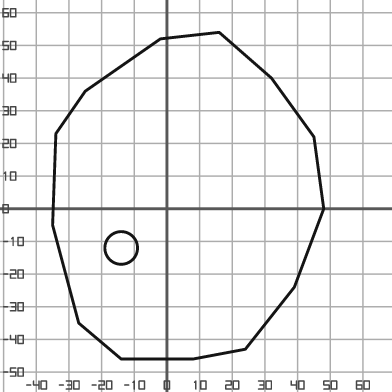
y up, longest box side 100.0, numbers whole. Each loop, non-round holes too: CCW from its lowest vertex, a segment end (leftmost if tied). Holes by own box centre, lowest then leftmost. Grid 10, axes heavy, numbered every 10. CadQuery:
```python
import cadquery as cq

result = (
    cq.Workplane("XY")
    .moveTo(-14.0, -46.0)
    .lineTo(8.0, -46.0)
    .lineTo(24.0, -43.0)
    .lineTo(39.0, -24.0)
    .lineTo(48.0, 0.0)
    .lineTo(45.0, 22.0)
    .lineTo(32.0, 40.0)
    .lineTo(16.0, 54.0)
    .lineTo(-2.0, 52.0)
    .lineTo(-25.0, 36.0)
    .lineTo(-34.0, 23.0)
    .lineTo(-35.0, -5.0)
    .lineTo(-27.0, -35.0)
    .close()
    .moveTo(-14.0, -12.0)
    .circle(5.0)
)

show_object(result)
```